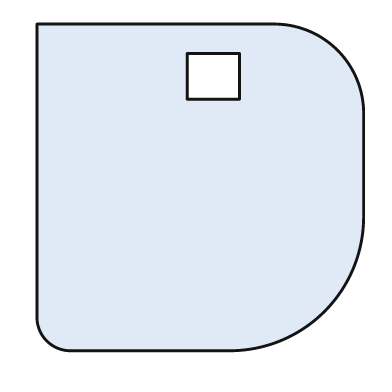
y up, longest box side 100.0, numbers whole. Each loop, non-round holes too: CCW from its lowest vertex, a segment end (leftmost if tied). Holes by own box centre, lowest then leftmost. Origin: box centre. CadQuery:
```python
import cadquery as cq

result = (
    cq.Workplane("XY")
    .moveTo(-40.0, -50.0)
    .lineTo(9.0, -50.0)
    .threePointArc((38.0, -38.0), (50.0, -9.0))
    .lineTo(50.0, 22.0)
    .threePointArc((42.0, 42.0), (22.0, 50.0))
    .lineTo(-50.0, 50.0)
    .lineTo(-50.0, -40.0)
    .threePointArc((-47.0, -47.0), (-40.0, -50.0))
    .close()
    .moveTo(-4.0, 27.0)
    .lineTo(12.0, 27.0)
    .lineTo(12.0, 41.0)
    .lineTo(-4.0, 41.0)
    .close()
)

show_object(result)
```